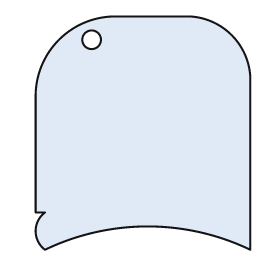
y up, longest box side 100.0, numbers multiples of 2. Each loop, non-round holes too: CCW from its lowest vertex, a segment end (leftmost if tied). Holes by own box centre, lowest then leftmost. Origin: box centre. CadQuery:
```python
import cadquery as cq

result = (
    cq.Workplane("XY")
    .moveTo(-42.0, -50.0)
    .threePointArc((2.0, -40.0), (46.0, -50.0))
    .lineTo(46.0, 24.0)
    .threePointArc((38.0, 42.0), (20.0, 50.0))
    .lineTo(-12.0, 50.0)
    .threePointArc((-36.0, 40.0), (-46.0, 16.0))
    .lineTo(-46.0, -34.0)
    .lineTo(-42.0, -34.0)
    .threePointArc((-46.0, -42.0), (-42.0, -50.0))
    .close()
    .moveTo(-22.0, 40.0)
    .circle(4.0)
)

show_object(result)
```